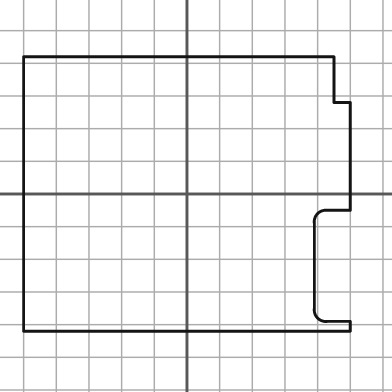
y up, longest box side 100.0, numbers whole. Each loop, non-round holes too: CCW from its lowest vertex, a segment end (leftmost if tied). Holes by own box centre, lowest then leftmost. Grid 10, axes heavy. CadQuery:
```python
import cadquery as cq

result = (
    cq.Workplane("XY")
    .moveTo(-50.0, -42.0)
    .lineTo(50.0, -42.0)
    .lineTo(50.0, -39.0)
    .lineTo(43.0, -39.0)
    .threePointArc((40.0, -38.0), (39.0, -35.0))
    .lineTo(39.0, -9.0)
    .threePointArc((40.0, -6.0), (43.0, -5.0))
    .lineTo(50.0, -5.0)
    .lineTo(50.0, 28.0)
    .lineTo(45.0, 28.0)
    .lineTo(45.0, 42.0)
    .lineTo(-50.0, 42.0)
    .close()
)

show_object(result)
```